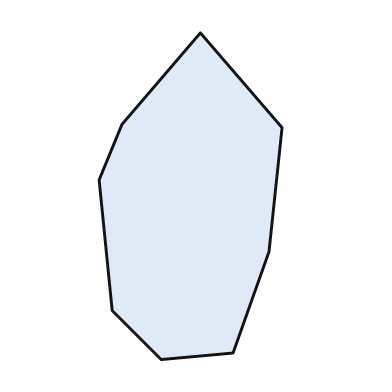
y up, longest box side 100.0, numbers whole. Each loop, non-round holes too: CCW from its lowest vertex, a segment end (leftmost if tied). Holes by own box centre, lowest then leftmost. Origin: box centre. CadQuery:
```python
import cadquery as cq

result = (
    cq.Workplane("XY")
    .moveTo(-9.0, -50.0)
    .lineTo(13.0, -48.0)
    .lineTo(24.0, -17.0)
    .lineTo(28.0, 21.0)
    .lineTo(3.0, 50.0)
    .lineTo(-21.0, 22.0)
    .lineTo(-28.0, 5.0)
    .lineTo(-24.0, -35.0)
    .close()
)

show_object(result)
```